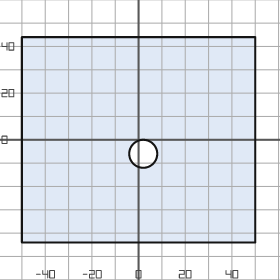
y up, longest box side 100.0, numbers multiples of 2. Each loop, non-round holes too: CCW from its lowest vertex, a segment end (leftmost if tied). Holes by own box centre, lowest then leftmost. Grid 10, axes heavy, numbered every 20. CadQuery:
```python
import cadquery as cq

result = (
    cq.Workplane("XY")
    .moveTo(-50.0, -44.0)
    .lineTo(50.0, -44.0)
    .lineTo(50.0, 44.0)
    .lineTo(-50.0, 44.0)
    .close()
    .moveTo(2.0, -6.0)
    .circle(6.0)
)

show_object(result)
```